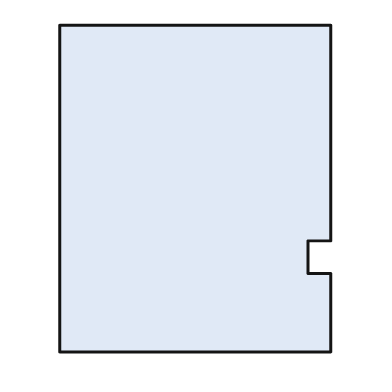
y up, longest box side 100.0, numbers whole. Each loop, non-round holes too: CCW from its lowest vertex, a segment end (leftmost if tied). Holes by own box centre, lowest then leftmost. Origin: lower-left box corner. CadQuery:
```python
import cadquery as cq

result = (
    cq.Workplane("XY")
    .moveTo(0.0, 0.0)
    .lineTo(83.0, 0.0)
    .lineTo(83.0, 24.0)
    .lineTo(76.0, 24.0)
    .lineTo(76.0, 34.0)
    .lineTo(83.0, 34.0)
    .lineTo(83.0, 100.0)
    .lineTo(0.0, 100.0)
    .close()
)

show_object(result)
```